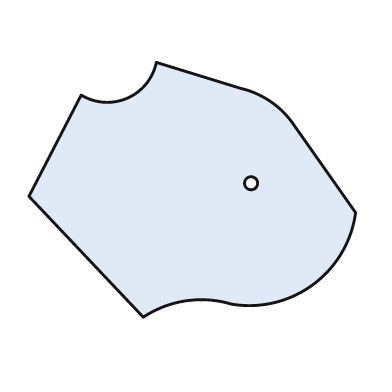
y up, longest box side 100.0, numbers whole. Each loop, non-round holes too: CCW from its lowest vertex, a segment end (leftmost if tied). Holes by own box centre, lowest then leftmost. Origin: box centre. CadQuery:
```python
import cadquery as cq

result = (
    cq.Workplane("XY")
    .moveTo(-15.0, -39.0)
    .threePointArc((-2.0, -34.0), (12.0, -35.0))
    .threePointArc((37.0, -29.0), (50.0, -7.0))
    .lineTo(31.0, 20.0)
    .threePointArc((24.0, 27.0), (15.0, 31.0))
    .lineTo(-11.0, 39.0)
    .threePointArc((-20.0, 28.0), (-34.0, 29.0))
    .lineTo(-50.0, -2.0)
    .close()
    .moveTo(18.0, 2.0)
    .circle(2.0)
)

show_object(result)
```